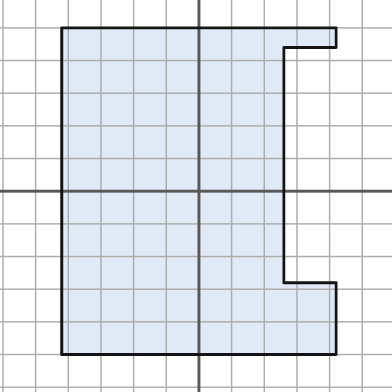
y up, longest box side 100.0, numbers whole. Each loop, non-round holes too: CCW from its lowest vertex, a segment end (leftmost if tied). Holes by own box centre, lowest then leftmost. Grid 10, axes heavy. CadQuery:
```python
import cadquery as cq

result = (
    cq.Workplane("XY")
    .moveTo(-42.0, -50.0)
    .lineTo(42.0, -50.0)
    .lineTo(42.0, -28.0)
    .lineTo(26.0, -28.0)
    .lineTo(26.0, 44.0)
    .lineTo(42.0, 44.0)
    .lineTo(42.0, 50.0)
    .lineTo(-42.0, 50.0)
    .close()
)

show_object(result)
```